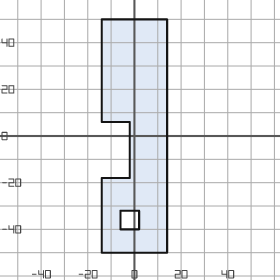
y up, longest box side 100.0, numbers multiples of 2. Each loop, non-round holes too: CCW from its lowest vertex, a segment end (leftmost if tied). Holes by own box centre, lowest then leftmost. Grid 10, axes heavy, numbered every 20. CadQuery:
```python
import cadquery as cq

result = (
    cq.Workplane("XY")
    .moveTo(-14.0, -50.0)
    .lineTo(14.0, -50.0)
    .lineTo(14.0, 50.0)
    .lineTo(-14.0, 50.0)
    .lineTo(-14.0, 6.0)
    .lineTo(-2.0, 6.0)
    .lineTo(-2.0, -18.0)
    .lineTo(-14.0, -18.0)
    .close()
    .moveTo(-6.0, -40.0)
    .lineTo(2.0, -40.0)
    .lineTo(2.0, -32.0)
    .lineTo(-6.0, -32.0)
    .close()
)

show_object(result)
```